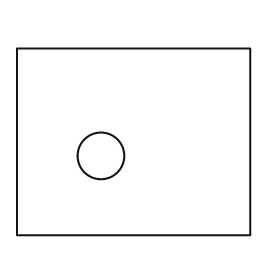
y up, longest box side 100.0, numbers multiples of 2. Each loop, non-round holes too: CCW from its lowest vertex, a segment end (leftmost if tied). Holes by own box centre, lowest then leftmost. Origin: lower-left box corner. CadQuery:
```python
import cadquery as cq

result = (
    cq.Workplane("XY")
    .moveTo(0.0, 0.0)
    .lineTo(100.0, 0.0)
    .lineTo(100.0, 80.0)
    .lineTo(0.0, 80.0)
    .close()
    .moveTo(36.0, 34.0)
    .circle(10.0)
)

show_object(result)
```